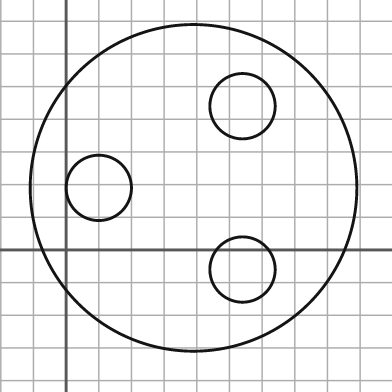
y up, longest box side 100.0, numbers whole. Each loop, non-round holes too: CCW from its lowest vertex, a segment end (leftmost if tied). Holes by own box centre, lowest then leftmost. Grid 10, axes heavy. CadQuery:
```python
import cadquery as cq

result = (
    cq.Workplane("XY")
    .moveTo(39.0, 19.0)
    .circle(50.0)
    .moveTo(54.0, -6.0)
    .circle(10.0)
    .moveTo(10.0, 19.0)
    .circle(10.0)
    .moveTo(54.0, 44.0)
    .circle(10.0)
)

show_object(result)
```